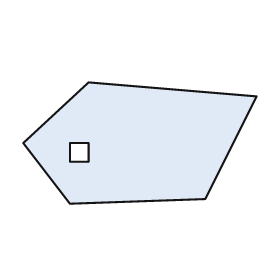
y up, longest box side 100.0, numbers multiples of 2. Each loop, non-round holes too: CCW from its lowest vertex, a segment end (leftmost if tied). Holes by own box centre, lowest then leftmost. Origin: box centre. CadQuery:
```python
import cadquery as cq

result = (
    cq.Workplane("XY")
    .moveTo(-30.0, -26.0)
    .lineTo(28.0, -24.0)
    .lineTo(50.0, 20.0)
    .lineTo(-22.0, 26.0)
    .lineTo(-50.0, 0.0)
    .close()
    .moveTo(-30.0, -8.0)
    .lineTo(-22.0, -8.0)
    .lineTo(-22.0, 0.0)
    .lineTo(-30.0, 0.0)
    .close()
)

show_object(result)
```